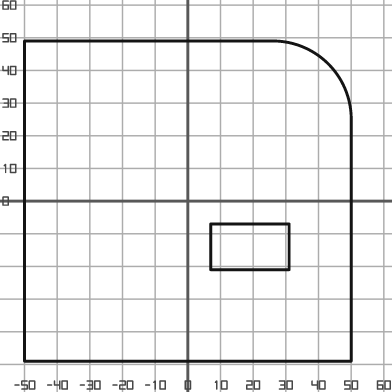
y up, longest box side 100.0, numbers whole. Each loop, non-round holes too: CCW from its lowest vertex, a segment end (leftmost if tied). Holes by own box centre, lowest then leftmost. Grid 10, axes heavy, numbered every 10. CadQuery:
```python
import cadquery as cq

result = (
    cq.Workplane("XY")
    .moveTo(-50.0, -49.0)
    .lineTo(50.0, -49.0)
    .lineTo(50.0, 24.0)
    .threePointArc((43.0, 42.0), (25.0, 49.0))
    .lineTo(-50.0, 49.0)
    .close()
    .moveTo(7.0, -21.0)
    .lineTo(31.0, -21.0)
    .lineTo(31.0, -7.0)
    .lineTo(7.0, -7.0)
    .close()
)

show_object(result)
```